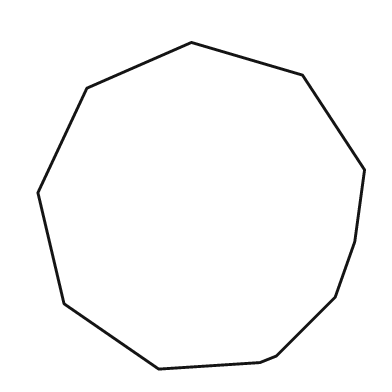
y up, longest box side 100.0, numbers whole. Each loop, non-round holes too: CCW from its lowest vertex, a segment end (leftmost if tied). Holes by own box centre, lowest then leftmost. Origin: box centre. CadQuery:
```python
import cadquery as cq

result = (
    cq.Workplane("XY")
    .moveTo(-13.0, -50.0)
    .lineTo(18.0, -48.0)
    .lineTo(23.0, -46.0)
    .lineTo(41.0, -28.0)
    .lineTo(47.0, -11.0)
    .lineTo(50.0, 11.0)
    .lineTo(31.0, 40.0)
    .lineTo(-3.0, 50.0)
    .lineTo(-35.0, 36.0)
    .lineTo(-50.0, 4.0)
    .lineTo(-42.0, -30.0)
    .close()
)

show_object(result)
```